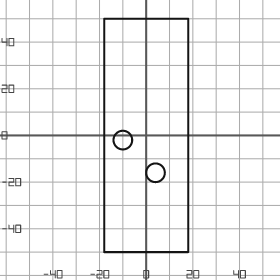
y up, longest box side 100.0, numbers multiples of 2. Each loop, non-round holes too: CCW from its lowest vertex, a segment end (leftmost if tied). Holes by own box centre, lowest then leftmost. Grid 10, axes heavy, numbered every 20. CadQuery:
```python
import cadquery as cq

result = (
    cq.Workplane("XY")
    .moveTo(-18.0, -50.0)
    .lineTo(18.0, -50.0)
    .lineTo(18.0, 50.0)
    .lineTo(-18.0, 50.0)
    .close()
    .moveTo(4.0, -16.0)
    .circle(4.0)
    .moveTo(-10.0, -2.0)
    .circle(4.0)
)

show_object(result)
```